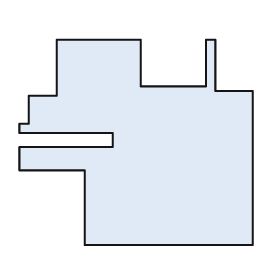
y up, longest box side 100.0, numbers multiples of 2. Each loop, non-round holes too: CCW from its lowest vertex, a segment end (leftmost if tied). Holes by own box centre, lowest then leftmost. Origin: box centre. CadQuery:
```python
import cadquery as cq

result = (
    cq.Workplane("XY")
    .moveTo(-22.0, -44.0)
    .lineTo(50.0, -44.0)
    .lineTo(50.0, 22.0)
    .lineTo(34.0, 22.0)
    .lineTo(34.0, 44.0)
    .lineTo(30.0, 44.0)
    .lineTo(30.0, 24.0)
    .lineTo(2.0, 24.0)
    .lineTo(2.0, 44.0)
    .lineTo(-34.0, 44.0)
    .lineTo(-34.0, 20.0)
    .lineTo(-46.0, 20.0)
    .lineTo(-46.0, 8.0)
    .lineTo(-50.0, 8.0)
    .lineTo(-50.0, 4.0)
    .lineTo(-10.0, 4.0)
    .lineTo(-10.0, -2.0)
    .lineTo(-50.0, -2.0)
    .lineTo(-50.0, -12.0)
    .lineTo(-22.0, -12.0)
    .close()
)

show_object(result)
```